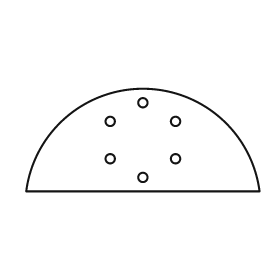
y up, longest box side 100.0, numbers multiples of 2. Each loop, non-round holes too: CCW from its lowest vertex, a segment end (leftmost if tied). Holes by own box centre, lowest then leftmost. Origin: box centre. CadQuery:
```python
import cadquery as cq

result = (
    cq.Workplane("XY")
    .moveTo(-50.0, -22.0)
    .lineTo(50.0, -22.0)
    .threePointArc((0.0, 22.0), (-50.0, -22.0))
    .close()
    .moveTo(0.0, -16.0)
    .circle(2.0)
    .moveTo(-14.0, -8.0)
    .circle(2.0)
    .moveTo(14.0, -8.0)
    .circle(2.0)
    .moveTo(-14.0, 8.0)
    .circle(2.0)
    .moveTo(14.0, 8.0)
    .circle(2.0)
    .moveTo(0.0, 16.0)
    .circle(2.0)
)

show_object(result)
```